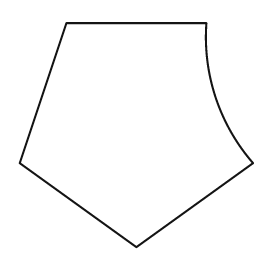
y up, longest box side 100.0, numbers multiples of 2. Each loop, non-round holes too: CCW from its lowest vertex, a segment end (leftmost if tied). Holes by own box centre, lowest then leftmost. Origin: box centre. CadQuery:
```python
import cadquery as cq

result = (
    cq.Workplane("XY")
    .moveTo(0.0, -48.0)
    .lineTo(50.0, -12.0)
    .threePointArc((34.0, 16.0), (30.0, 48.0))
    .lineTo(-30.0, 48.0)
    .lineTo(-50.0, -12.0)
    .close()
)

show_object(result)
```